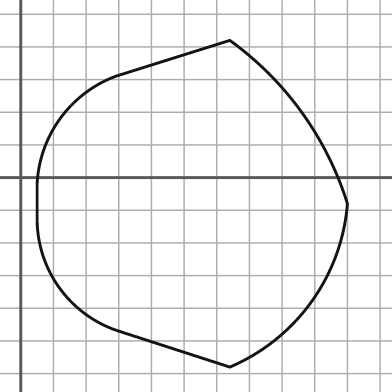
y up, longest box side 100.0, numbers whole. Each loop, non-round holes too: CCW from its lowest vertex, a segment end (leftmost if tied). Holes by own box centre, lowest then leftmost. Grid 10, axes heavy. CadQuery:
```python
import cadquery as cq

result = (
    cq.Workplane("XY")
    .moveTo(64.0, -58.0)
    .threePointArc((89.0, -38.0), (100.0, -8.0))
    .threePointArc((86.0, 20.0), (64.0, 42.0))
    .lineTo(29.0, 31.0)
    .threePointArc((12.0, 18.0), (5.0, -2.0))
    .lineTo(5.0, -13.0)
    .threePointArc((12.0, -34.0), (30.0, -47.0))
    .close()
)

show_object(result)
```